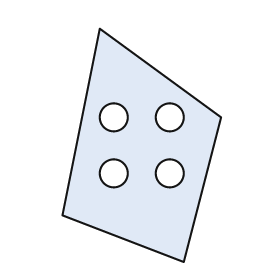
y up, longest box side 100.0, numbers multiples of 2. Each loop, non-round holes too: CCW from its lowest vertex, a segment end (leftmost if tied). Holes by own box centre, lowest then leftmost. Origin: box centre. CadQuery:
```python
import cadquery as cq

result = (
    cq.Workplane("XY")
    .moveTo(18.0, -50.0)
    .lineTo(34.0, 12.0)
    .lineTo(-18.0, 50.0)
    .lineTo(-34.0, -30.0)
    .close()
    .moveTo(-12.0, -12.0)
    .circle(6.0)
    .moveTo(12.0, -12.0)
    .circle(6.0)
    .moveTo(-12.0, 12.0)
    .circle(6.0)
    .moveTo(12.0, 12.0)
    .circle(6.0)
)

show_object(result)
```